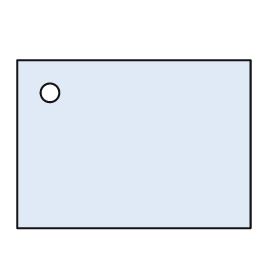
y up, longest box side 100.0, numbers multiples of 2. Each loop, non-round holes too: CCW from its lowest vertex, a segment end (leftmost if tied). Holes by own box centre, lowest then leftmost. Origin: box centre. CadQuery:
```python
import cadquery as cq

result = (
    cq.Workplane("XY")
    .moveTo(-50.0, -36.0)
    .lineTo(50.0, -36.0)
    .lineTo(50.0, 36.0)
    .lineTo(-50.0, 36.0)
    .close()
    .moveTo(-36.0, 22.0)
    .circle(4.0)
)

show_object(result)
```